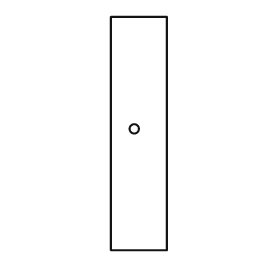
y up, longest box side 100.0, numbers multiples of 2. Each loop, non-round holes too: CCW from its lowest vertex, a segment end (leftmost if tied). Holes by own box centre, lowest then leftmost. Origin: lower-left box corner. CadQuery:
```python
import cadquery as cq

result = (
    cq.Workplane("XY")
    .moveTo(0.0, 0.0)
    .lineTo(24.0, 0.0)
    .lineTo(24.0, 100.0)
    .lineTo(0.0, 100.0)
    .close()
    .moveTo(10.0, 52.0)
    .circle(2.0)
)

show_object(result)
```